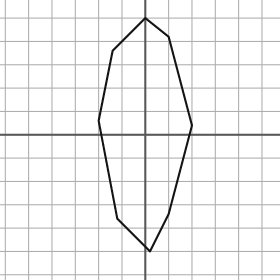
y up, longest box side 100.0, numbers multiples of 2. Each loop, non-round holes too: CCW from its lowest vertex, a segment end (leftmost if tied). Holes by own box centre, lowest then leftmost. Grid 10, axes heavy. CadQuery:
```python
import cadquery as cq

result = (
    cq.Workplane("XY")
    .moveTo(2.0, -50.0)
    .lineTo(10.0, -34.0)
    .lineTo(20.0, 4.0)
    .lineTo(10.0, 42.0)
    .lineTo(0.0, 50.0)
    .lineTo(-14.0, 36.0)
    .lineTo(-20.0, 6.0)
    .lineTo(-12.0, -36.0)
    .close()
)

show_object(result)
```